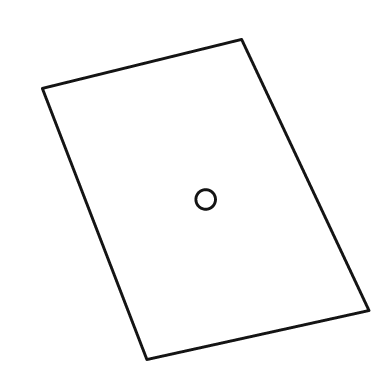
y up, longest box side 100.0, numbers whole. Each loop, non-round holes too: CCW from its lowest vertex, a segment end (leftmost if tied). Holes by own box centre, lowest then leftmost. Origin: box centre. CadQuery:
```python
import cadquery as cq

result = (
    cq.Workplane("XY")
    .moveTo(-18.0, -49.0)
    .lineTo(50.0, -34.0)
    .lineTo(11.0, 49.0)
    .lineTo(-50.0, 34.0)
    .close()
    .moveTo(0.0, 0.0)
    .circle(3.0)
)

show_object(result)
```